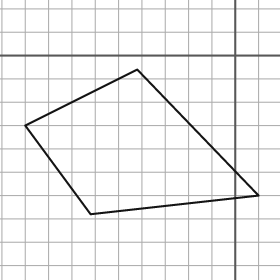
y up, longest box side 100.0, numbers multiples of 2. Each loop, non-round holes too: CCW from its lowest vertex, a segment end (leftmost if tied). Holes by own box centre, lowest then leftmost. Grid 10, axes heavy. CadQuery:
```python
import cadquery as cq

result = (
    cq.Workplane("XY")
    .moveTo(-62.0, -68.0)
    .lineTo(10.0, -60.0)
    .lineTo(-42.0, -6.0)
    .lineTo(-90.0, -30.0)
    .close()
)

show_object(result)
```